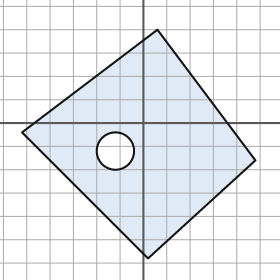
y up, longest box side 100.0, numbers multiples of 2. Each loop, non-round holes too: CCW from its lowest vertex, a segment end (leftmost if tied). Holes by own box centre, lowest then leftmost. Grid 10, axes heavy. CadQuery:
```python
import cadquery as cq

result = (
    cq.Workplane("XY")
    .moveTo(2.0, -58.0)
    .lineTo(48.0, -16.0)
    .lineTo(6.0, 40.0)
    .lineTo(-52.0, -4.0)
    .close()
    .moveTo(-12.0, -12.0)
    .circle(8.0)
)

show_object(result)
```